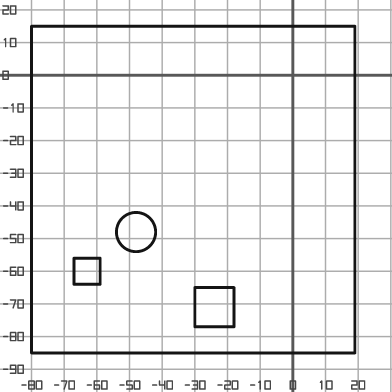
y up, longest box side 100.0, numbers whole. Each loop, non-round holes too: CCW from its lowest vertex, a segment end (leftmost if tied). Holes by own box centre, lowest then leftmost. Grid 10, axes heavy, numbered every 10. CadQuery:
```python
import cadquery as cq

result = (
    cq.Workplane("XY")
    .moveTo(-80.0, -85.0)
    .lineTo(19.0, -85.0)
    .lineTo(19.0, 15.0)
    .lineTo(-80.0, 15.0)
    .close()
    .moveTo(-30.0, -77.0)
    .lineTo(-18.0, -77.0)
    .lineTo(-18.0, -65.0)
    .lineTo(-30.0, -65.0)
    .close()
    .moveTo(-67.0, -64.0)
    .lineTo(-59.0, -64.0)
    .lineTo(-59.0, -56.0)
    .lineTo(-67.0, -56.0)
    .close()
    .moveTo(-48.0, -48.0)
    .circle(6.0)
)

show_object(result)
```